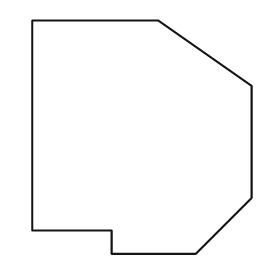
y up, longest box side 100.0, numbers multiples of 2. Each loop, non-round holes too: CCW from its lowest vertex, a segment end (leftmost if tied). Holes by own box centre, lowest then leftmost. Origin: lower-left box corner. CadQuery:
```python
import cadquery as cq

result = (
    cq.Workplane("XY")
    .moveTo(34.0, 0.0)
    .lineTo(70.0, 0.0)
    .lineTo(94.0, 24.0)
    .lineTo(94.0, 72.0)
    .lineTo(54.0, 100.0)
    .lineTo(0.0, 100.0)
    .lineTo(0.0, 10.0)
    .lineTo(34.0, 10.0)
    .close()
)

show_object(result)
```